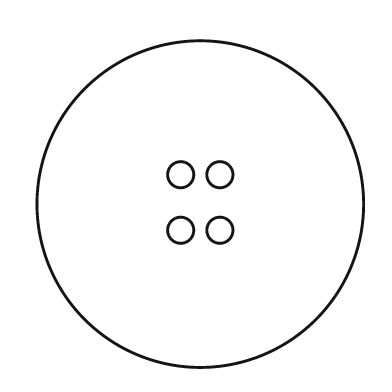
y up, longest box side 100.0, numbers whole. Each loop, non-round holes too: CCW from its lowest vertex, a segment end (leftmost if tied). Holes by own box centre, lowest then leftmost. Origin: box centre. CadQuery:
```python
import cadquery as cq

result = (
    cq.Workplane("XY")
    .moveTo(0.0, 0.0)
    .circle(50.0)
    .moveTo(-6.0, -8.0)
    .circle(4.0)
    .moveTo(6.0, -8.0)
    .circle(4.0)
    .moveTo(-6.0, 9.0)
    .circle(4.0)
    .moveTo(6.0, 9.0)
    .circle(4.0)
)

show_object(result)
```